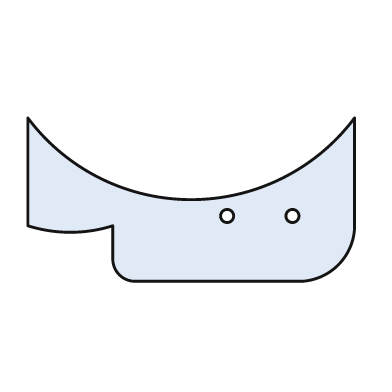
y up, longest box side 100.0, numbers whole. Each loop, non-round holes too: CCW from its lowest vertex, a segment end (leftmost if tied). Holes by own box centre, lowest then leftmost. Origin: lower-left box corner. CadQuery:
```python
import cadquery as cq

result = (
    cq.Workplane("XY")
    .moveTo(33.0, 0.0)
    .lineTo(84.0, 0.0)
    .threePointArc((95.0, 5.0), (100.0, 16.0))
    .lineTo(100.0, 50.0)
    .threePointArc((50.0, 25.0), (0.0, 50.0))
    .lineTo(0.0, 17.0)
    .threePointArc((13.0, 15.0), (26.0, 17.0))
    .lineTo(26.0, 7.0)
    .threePointArc((28.0, 2.0), (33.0, 0.0))
    .close()
    .moveTo(61.0, 20.0)
    .circle(2.0)
    .moveTo(81.0, 20.0)
    .circle(2.0)
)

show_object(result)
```